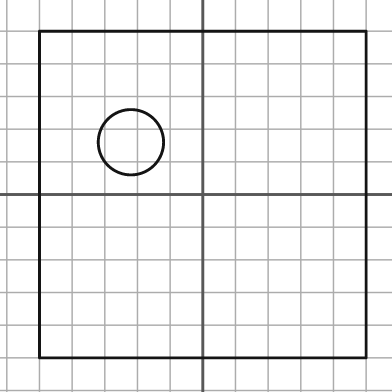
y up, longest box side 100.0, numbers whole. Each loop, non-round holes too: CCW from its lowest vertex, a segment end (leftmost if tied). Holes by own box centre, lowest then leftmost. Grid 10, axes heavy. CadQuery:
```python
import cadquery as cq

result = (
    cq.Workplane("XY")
    .moveTo(-50.0, -50.0)
    .lineTo(50.0, -50.0)
    .lineTo(50.0, 50.0)
    .lineTo(-50.0, 50.0)
    .close()
    .moveTo(-22.0, 16.0)
    .circle(10.0)
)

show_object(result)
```